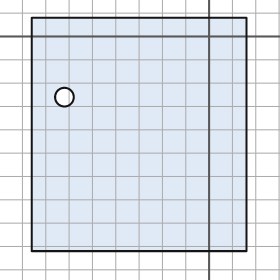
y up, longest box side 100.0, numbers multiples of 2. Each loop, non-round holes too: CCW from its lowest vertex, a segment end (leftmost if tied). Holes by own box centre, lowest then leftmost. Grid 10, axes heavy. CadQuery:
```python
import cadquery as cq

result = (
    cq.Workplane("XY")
    .moveTo(-76.0, -92.0)
    .lineTo(16.0, -92.0)
    .lineTo(16.0, 8.0)
    .lineTo(-76.0, 8.0)
    .close()
    .moveTo(-62.0, -26.0)
    .circle(4.0)
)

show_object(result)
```